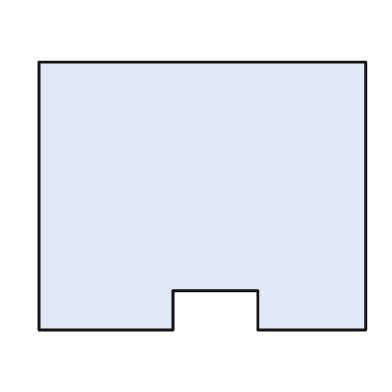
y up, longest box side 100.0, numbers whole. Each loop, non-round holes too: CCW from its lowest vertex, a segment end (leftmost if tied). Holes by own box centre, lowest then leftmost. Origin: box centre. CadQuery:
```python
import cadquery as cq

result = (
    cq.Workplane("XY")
    .moveTo(-50.0, -41.0)
    .lineTo(-9.0, -41.0)
    .lineTo(-9.0, -29.0)
    .lineTo(17.0, -29.0)
    .lineTo(17.0, -41.0)
    .lineTo(50.0, -41.0)
    .lineTo(50.0, 41.0)
    .lineTo(-50.0, 41.0)
    .close()
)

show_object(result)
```